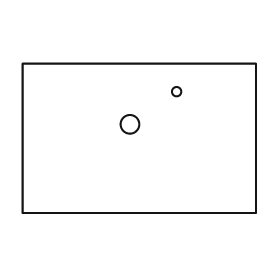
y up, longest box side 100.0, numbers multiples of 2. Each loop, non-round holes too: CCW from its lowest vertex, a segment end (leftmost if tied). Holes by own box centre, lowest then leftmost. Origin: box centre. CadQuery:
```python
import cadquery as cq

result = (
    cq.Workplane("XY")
    .moveTo(-50.0, -32.0)
    .lineTo(50.0, -32.0)
    .lineTo(50.0, 32.0)
    .lineTo(-50.0, 32.0)
    .close()
    .moveTo(-4.0, 6.0)
    .circle(4.0)
    .moveTo(16.0, 20.0)
    .circle(2.0)
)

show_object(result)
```